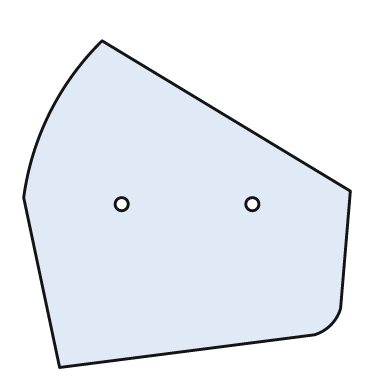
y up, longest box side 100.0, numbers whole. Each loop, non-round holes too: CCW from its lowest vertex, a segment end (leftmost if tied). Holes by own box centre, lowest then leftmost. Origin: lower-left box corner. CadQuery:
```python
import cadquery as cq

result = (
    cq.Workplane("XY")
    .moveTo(11.0, 0.0)
    .lineTo(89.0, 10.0)
    .threePointArc((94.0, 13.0), (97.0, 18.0))
    .lineTo(100.0, 54.0)
    .lineTo(24.0, 100.0)
    .threePointArc((8.0, 78.0), (0.0, 52.0))
    .close()
    .moveTo(30.0, 50.0)
    .circle(2.0)
    .moveTo(70.0, 50.0)
    .circle(2.0)
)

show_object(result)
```